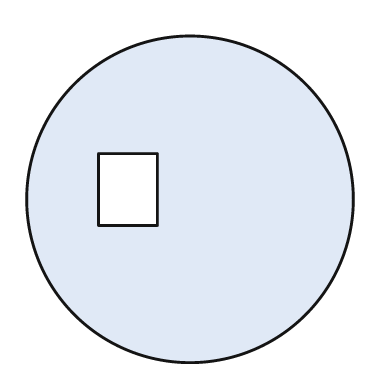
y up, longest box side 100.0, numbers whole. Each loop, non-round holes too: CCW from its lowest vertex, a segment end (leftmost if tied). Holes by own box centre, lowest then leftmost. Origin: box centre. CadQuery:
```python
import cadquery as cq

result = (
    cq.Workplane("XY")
    .moveTo(0.0, 0.0)
    .circle(50.0)
    .moveTo(-28.0, -8.0)
    .lineTo(-10.0, -8.0)
    .lineTo(-10.0, 14.0)
    .lineTo(-28.0, 14.0)
    .close()
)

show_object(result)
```